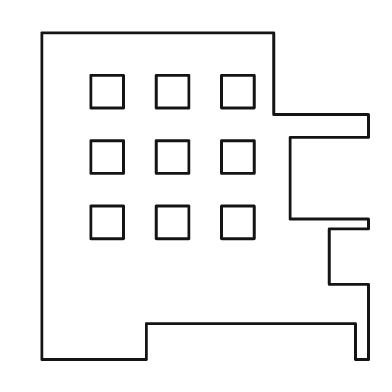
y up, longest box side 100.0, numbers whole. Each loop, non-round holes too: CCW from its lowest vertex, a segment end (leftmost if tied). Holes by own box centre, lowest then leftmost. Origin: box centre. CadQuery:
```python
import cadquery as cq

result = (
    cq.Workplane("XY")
    .moveTo(-50.0, -50.0)
    .lineTo(-18.0, -50.0)
    .lineTo(-18.0, -39.0)
    .lineTo(46.0, -39.0)
    .lineTo(46.0, -50.0)
    .lineTo(50.0, -50.0)
    .lineTo(50.0, -27.0)
    .lineTo(38.0, -27.0)
    .lineTo(38.0, -10.0)
    .lineTo(50.0, -10.0)
    .lineTo(50.0, -7.0)
    .lineTo(26.0, -7.0)
    .lineTo(26.0, 18.0)
    .lineTo(50.0, 18.0)
    .lineTo(50.0, 25.0)
    .lineTo(21.0, 25.0)
    .lineTo(21.0, 50.0)
    .lineTo(-50.0, 50.0)
    .close()
    .moveTo(-35.0, -13.0)
    .lineTo(-25.0, -13.0)
    .lineTo(-25.0, -3.0)
    .lineTo(-35.0, -3.0)
    .close()
    .moveTo(-15.0, -13.0)
    .lineTo(-5.0, -13.0)
    .lineTo(-5.0, -3.0)
    .lineTo(-15.0, -3.0)
    .close()
    .moveTo(5.0, -13.0)
    .lineTo(15.0, -13.0)
    .lineTo(15.0, -3.0)
    .lineTo(5.0, -3.0)
    .close()
    .moveTo(-35.0, 7.0)
    .lineTo(-25.0, 7.0)
    .lineTo(-25.0, 17.0)
    .lineTo(-35.0, 17.0)
    .close()
    .moveTo(-15.0, 7.0)
    .lineTo(-5.0, 7.0)
    .lineTo(-5.0, 17.0)
    .lineTo(-15.0, 17.0)
    .close()
    .moveTo(5.0, 7.0)
    .lineTo(15.0, 7.0)
    .lineTo(15.0, 17.0)
    .lineTo(5.0, 17.0)
    .close()
    .moveTo(-35.0, 27.0)
    .lineTo(-25.0, 27.0)
    .lineTo(-25.0, 37.0)
    .lineTo(-35.0, 37.0)
    .close()
    .moveTo(-15.0, 27.0)
    .lineTo(-5.0, 27.0)
    .lineTo(-5.0, 37.0)
    .lineTo(-15.0, 37.0)
    .close()
    .moveTo(5.0, 27.0)
    .lineTo(15.0, 27.0)
    .lineTo(15.0, 37.0)
    .lineTo(5.0, 37.0)
    .close()
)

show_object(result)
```